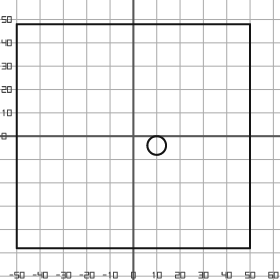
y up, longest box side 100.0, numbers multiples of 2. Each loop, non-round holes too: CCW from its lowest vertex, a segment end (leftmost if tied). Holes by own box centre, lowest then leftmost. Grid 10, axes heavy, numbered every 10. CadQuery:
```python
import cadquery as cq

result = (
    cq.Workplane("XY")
    .moveTo(-50.0, -48.0)
    .lineTo(50.0, -48.0)
    .lineTo(50.0, 48.0)
    .lineTo(-50.0, 48.0)
    .close()
    .moveTo(10.0, -4.0)
    .circle(4.0)
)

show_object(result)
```